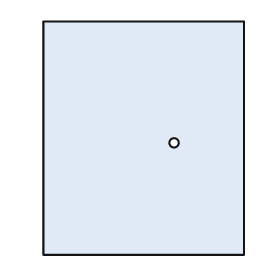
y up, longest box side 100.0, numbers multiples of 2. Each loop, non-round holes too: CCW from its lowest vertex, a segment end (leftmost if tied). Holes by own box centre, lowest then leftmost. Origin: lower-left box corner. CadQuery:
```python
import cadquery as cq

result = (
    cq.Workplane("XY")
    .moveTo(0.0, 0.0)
    .lineTo(86.0, 0.0)
    .lineTo(86.0, 100.0)
    .lineTo(0.0, 100.0)
    .close()
    .moveTo(56.0, 48.0)
    .circle(2.0)
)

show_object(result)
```